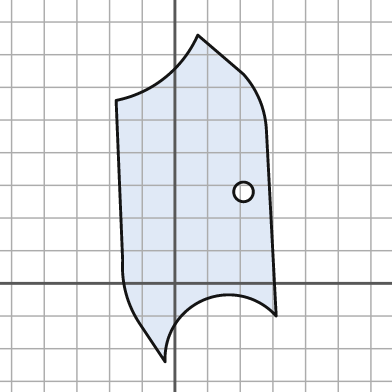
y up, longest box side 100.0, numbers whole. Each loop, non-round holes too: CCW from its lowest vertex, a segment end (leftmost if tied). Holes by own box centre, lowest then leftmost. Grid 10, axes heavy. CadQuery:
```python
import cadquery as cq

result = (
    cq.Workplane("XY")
    .moveTo(-3.0, -24.0)
    .threePointArc((9.0, -5.0), (31.0, -10.0))
    .lineTo(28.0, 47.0)
    .threePointArc((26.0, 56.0), (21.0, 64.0))
    .lineTo(7.0, 76.0)
    .threePointArc((-3.0, 63.0), (-18.0, 56.0))
    .lineTo(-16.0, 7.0)
    .threePointArc((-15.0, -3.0), (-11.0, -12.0))
    .close()
    .moveTo(21.0, 28.0)
    .circle(3.0)
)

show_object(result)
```